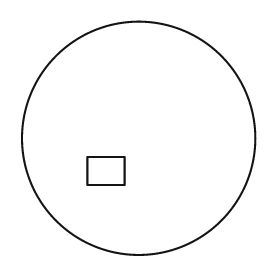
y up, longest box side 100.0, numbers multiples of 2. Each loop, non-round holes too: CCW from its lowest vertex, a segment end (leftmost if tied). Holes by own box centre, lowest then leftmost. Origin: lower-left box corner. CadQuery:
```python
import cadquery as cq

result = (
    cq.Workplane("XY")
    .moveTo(50.0, 50.0)
    .circle(50.0)
    .moveTo(28.0, 30.0)
    .lineTo(44.0, 30.0)
    .lineTo(44.0, 42.0)
    .lineTo(28.0, 42.0)
    .close()
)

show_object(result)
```